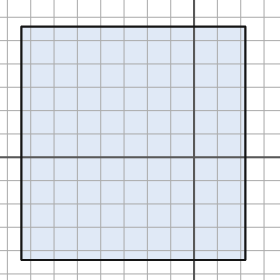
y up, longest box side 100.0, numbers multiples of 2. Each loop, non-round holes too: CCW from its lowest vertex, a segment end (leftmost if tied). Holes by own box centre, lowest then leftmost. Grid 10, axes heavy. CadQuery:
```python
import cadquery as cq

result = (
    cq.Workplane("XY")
    .moveTo(-74.0, -44.0)
    .lineTo(22.0, -44.0)
    .lineTo(22.0, 56.0)
    .lineTo(-74.0, 56.0)
    .close()
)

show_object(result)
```